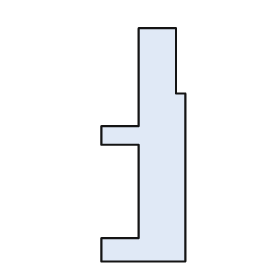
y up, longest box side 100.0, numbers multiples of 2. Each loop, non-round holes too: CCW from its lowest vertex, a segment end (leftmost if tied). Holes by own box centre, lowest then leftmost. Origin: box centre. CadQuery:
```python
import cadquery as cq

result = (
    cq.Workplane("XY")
    .moveTo(-18.0, -50.0)
    .lineTo(18.0, -50.0)
    .lineTo(18.0, 22.0)
    .lineTo(14.0, 22.0)
    .lineTo(14.0, 50.0)
    .lineTo(-2.0, 50.0)
    .lineTo(-2.0, 8.0)
    .lineTo(-18.0, 8.0)
    .lineTo(-18.0, 0.0)
    .lineTo(-2.0, 0.0)
    .lineTo(-2.0, -40.0)
    .lineTo(-18.0, -40.0)
    .close()
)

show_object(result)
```